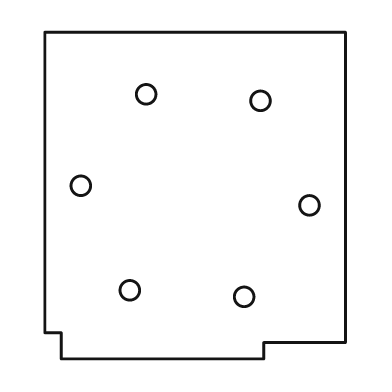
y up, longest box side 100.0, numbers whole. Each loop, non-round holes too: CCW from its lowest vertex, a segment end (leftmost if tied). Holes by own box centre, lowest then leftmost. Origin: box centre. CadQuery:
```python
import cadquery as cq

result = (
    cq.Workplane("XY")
    .moveTo(-41.0, -50.0)
    .lineTo(21.0, -50.0)
    .lineTo(21.0, -45.0)
    .lineTo(46.0, -45.0)
    .lineTo(46.0, 50.0)
    .lineTo(-46.0, 50.0)
    .lineTo(-46.0, -42.0)
    .lineTo(-41.0, -42.0)
    .close()
    .moveTo(15.0, -31.0)
    .circle(3.0)
    .moveTo(-20.0, -29.0)
    .circle(3.0)
    .moveTo(35.0, -3.0)
    .circle(3.0)
    .moveTo(-35.0, 3.0)
    .circle(3.0)
    .moveTo(20.0, 29.0)
    .circle(3.0)
    .moveTo(-15.0, 31.0)
    .circle(3.0)
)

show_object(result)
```